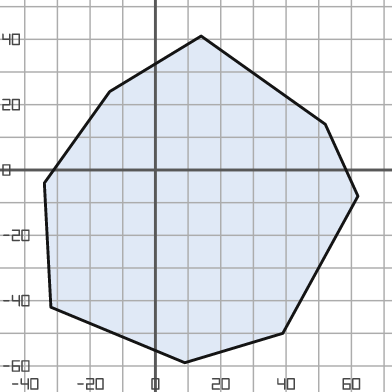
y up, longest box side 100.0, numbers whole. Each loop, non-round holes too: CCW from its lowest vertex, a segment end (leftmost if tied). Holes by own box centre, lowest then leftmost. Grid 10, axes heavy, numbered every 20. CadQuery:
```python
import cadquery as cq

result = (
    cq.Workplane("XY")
    .moveTo(9.0, -59.0)
    .lineTo(39.0, -50.0)
    .lineTo(62.0, -8.0)
    .lineTo(52.0, 14.0)
    .lineTo(14.0, 41.0)
    .lineTo(-14.0, 24.0)
    .lineTo(-34.0, -4.0)
    .lineTo(-32.0, -42.0)
    .close()
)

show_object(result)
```